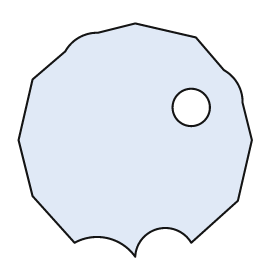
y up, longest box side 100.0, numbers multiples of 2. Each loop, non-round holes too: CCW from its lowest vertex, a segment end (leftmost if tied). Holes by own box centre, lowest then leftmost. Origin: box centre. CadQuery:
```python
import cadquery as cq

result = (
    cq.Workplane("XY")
    .moveTo(0.0, -50.0)
    .threePointArc((10.0, -38.0), (24.0, -44.0))
    .lineTo(44.0, -26.0)
    .lineTo(50.0, 0.0)
    .lineTo(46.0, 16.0)
    .threePointArc((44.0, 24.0), (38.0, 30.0))
    .lineTo(26.0, 44.0)
    .lineTo(0.0, 50.0)
    .lineTo(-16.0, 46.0)
    .threePointArc((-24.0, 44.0), (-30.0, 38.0))
    .lineTo(-44.0, 26.0)
    .lineTo(-50.0, 0.0)
    .lineTo(-44.0, -24.0)
    .lineTo(-26.0, -44.0)
    .threePointArc((-12.0, -42.0), (0.0, -50.0))
    .close()
    .moveTo(24.0, 14.0)
    .circle(8.0)
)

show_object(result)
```